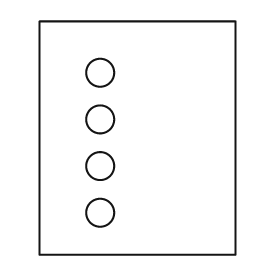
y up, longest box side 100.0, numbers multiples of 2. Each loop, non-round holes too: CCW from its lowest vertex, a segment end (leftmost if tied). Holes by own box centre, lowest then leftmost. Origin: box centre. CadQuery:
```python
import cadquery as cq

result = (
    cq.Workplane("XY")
    .moveTo(-42.0, -50.0)
    .lineTo(42.0, -50.0)
    .lineTo(42.0, 50.0)
    .lineTo(-42.0, 50.0)
    .close()
    .moveTo(-16.0, -32.0)
    .circle(6.0)
    .moveTo(-16.0, -12.0)
    .circle(6.0)
    .moveTo(-16.0, 8.0)
    .circle(6.0)
    .moveTo(-16.0, 28.0)
    .circle(6.0)
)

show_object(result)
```